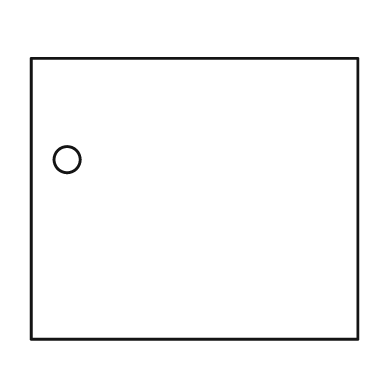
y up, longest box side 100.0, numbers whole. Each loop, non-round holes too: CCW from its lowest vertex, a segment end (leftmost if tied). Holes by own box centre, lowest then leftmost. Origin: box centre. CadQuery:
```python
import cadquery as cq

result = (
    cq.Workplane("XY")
    .moveTo(-50.0, -43.0)
    .lineTo(50.0, -43.0)
    .lineTo(50.0, 43.0)
    .lineTo(-50.0, 43.0)
    .close()
    .moveTo(-39.0, 12.0)
    .circle(4.0)
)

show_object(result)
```